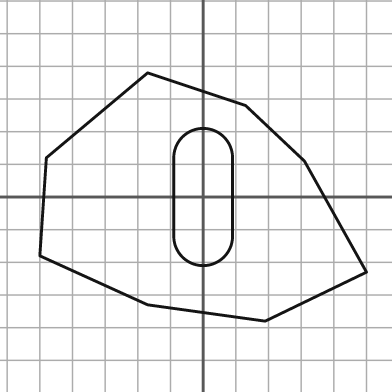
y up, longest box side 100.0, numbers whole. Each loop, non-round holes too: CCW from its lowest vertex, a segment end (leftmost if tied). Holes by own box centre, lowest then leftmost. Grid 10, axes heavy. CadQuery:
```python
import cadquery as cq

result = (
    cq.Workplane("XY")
    .moveTo(19.0, -38.0)
    .lineTo(50.0, -23.0)
    .lineTo(31.0, 11.0)
    .lineTo(13.0, 28.0)
    .lineTo(-17.0, 38.0)
    .lineTo(-48.0, 12.0)
    .lineTo(-50.0, -18.0)
    .lineTo(-17.0, -33.0)
    .close()
    .moveTo(-9.0, -12.0)
    .threePointArc((0.0, -21.0), (9.0, -12.0))
    .lineTo(9.0, 12.0)
    .threePointArc((0.0, 21.0), (-9.0, 12.0))
    .close()
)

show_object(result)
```